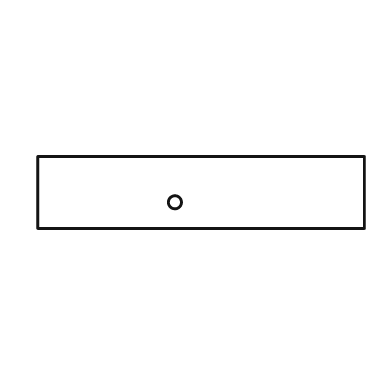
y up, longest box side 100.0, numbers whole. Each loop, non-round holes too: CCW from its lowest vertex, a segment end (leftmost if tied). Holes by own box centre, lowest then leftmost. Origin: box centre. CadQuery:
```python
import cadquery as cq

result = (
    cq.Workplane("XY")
    .moveTo(-50.0, -11.0)
    .lineTo(50.0, -11.0)
    .lineTo(50.0, 11.0)
    .lineTo(-50.0, 11.0)
    .close()
    .moveTo(-8.0, -3.0)
    .circle(2.0)
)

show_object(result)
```